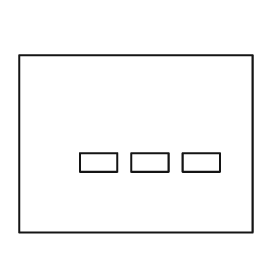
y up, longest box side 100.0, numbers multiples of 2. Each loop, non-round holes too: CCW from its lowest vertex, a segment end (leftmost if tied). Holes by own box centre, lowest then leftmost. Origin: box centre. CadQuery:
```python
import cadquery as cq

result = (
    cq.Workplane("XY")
    .moveTo(-50.0, -38.0)
    .lineTo(50.0, -38.0)
    .lineTo(50.0, 38.0)
    .lineTo(-50.0, 38.0)
    .close()
    .moveTo(-24.0, -12.0)
    .lineTo(-8.0, -12.0)
    .lineTo(-8.0, -4.0)
    .lineTo(-24.0, -4.0)
    .close()
    .moveTo(-2.0, -12.0)
    .lineTo(14.0, -12.0)
    .lineTo(14.0, -4.0)
    .lineTo(-2.0, -4.0)
    .close()
    .moveTo(20.0, -12.0)
    .lineTo(36.0, -12.0)
    .lineTo(36.0, -4.0)
    .lineTo(20.0, -4.0)
    .close()
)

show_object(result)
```